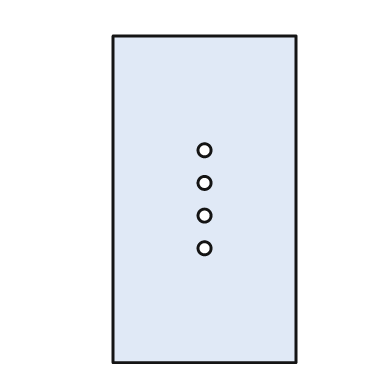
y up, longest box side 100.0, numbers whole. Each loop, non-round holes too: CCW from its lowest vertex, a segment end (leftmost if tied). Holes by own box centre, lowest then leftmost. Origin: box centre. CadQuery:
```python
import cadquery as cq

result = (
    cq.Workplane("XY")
    .moveTo(-28.0, -50.0)
    .lineTo(28.0, -50.0)
    .lineTo(28.0, 50.0)
    .lineTo(-28.0, 50.0)
    .close()
    .moveTo(0.0, -15.0)
    .circle(2.0)
    .moveTo(0.0, -5.0)
    .circle(2.0)
    .moveTo(0.0, 5.0)
    .circle(2.0)
    .moveTo(0.0, 15.0)
    .circle(2.0)
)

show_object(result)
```